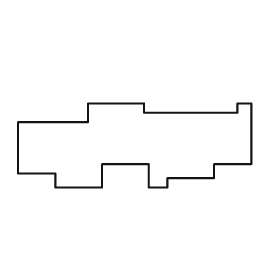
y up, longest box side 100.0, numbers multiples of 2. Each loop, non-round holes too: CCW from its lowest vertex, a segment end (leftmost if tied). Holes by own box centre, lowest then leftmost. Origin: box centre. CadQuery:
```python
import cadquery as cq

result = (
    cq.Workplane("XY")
    .moveTo(-34.0, -18.0)
    .lineTo(-14.0, -18.0)
    .lineTo(-14.0, -8.0)
    .lineTo(6.0, -8.0)
    .lineTo(6.0, -18.0)
    .lineTo(14.0, -18.0)
    .lineTo(14.0, -14.0)
    .lineTo(34.0, -14.0)
    .lineTo(34.0, -8.0)
    .lineTo(50.0, -8.0)
    .lineTo(50.0, 18.0)
    .lineTo(44.0, 18.0)
    .lineTo(44.0, 14.0)
    .lineTo(4.0, 14.0)
    .lineTo(4.0, 18.0)
    .lineTo(-20.0, 18.0)
    .lineTo(-20.0, 10.0)
    .lineTo(-50.0, 10.0)
    .lineTo(-50.0, -12.0)
    .lineTo(-34.0, -12.0)
    .close()
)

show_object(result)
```